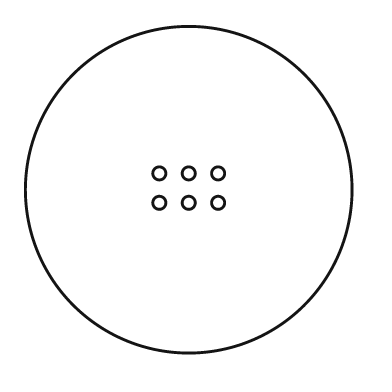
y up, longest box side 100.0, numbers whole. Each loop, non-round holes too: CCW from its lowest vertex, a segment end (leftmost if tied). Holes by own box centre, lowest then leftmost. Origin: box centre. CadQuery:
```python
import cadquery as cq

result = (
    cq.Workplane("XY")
    .moveTo(0.0, 0.0)
    .circle(50.0)
    .moveTo(-9.0, -4.0)
    .circle(2.0)
    .moveTo(0.0, -4.0)
    .circle(2.0)
    .moveTo(9.0, -4.0)
    .circle(2.0)
    .moveTo(-9.0, 5.0)
    .circle(2.0)
    .moveTo(0.0, 5.0)
    .circle(2.0)
    .moveTo(9.0, 5.0)
    .circle(2.0)
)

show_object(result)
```